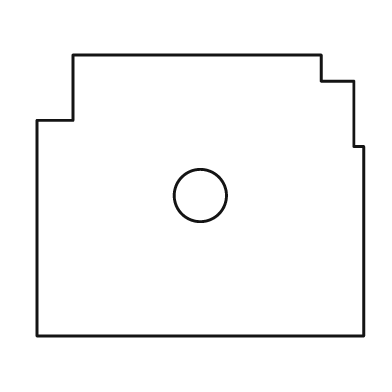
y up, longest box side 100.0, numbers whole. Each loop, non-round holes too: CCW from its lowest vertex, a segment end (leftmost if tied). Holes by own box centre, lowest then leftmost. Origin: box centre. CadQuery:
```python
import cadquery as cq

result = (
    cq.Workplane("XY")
    .moveTo(-50.0, -43.0)
    .lineTo(50.0, -43.0)
    .lineTo(50.0, 15.0)
    .lineTo(47.0, 15.0)
    .lineTo(47.0, 35.0)
    .lineTo(37.0, 35.0)
    .lineTo(37.0, 43.0)
    .lineTo(-39.0, 43.0)
    .lineTo(-39.0, 23.0)
    .lineTo(-50.0, 23.0)
    .close()
    .moveTo(0.0, 0.0)
    .circle(8.0)
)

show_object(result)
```